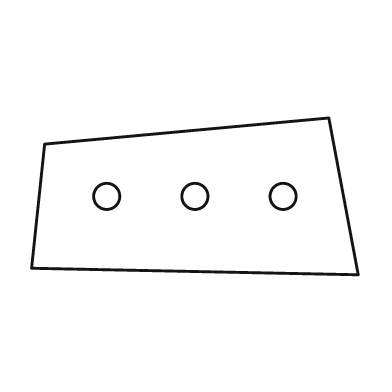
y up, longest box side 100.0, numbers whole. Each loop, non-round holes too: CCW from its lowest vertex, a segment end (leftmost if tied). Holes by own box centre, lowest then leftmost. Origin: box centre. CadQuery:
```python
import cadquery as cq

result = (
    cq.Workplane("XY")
    .moveTo(50.0, -24.0)
    .lineTo(41.0, 24.0)
    .lineTo(-46.0, 16.0)
    .lineTo(-50.0, -22.0)
    .close()
    .moveTo(-27.0, 0.0)
    .circle(4.0)
    .moveTo(0.0, 0.0)
    .circle(4.0)
    .moveTo(27.0, 0.0)
    .circle(4.0)
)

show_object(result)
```